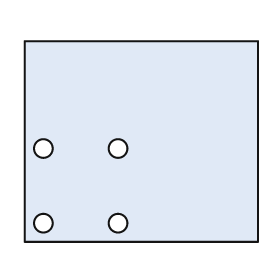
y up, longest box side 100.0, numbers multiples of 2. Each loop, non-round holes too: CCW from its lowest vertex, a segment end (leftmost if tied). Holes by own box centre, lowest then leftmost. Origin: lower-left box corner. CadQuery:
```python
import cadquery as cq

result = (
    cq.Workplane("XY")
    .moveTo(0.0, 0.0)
    .lineTo(100.0, 0.0)
    .lineTo(100.0, 86.0)
    .lineTo(0.0, 86.0)
    .close()
    .moveTo(8.0, 8.0)
    .circle(4.0)
    .moveTo(40.0, 8.0)
    .circle(4.0)
    .moveTo(8.0, 40.0)
    .circle(4.0)
    .moveTo(40.0, 40.0)
    .circle(4.0)
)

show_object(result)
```